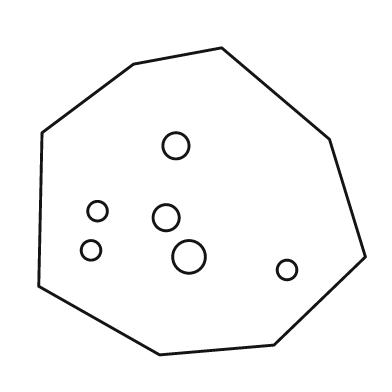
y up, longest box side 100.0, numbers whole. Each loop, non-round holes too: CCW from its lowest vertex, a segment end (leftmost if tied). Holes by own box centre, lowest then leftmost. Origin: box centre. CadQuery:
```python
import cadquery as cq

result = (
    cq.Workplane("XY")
    .moveTo(-13.0, -47.0)
    .lineTo(22.0, -44.0)
    .lineTo(50.0, -17.0)
    .lineTo(39.0, 19.0)
    .lineTo(6.0, 47.0)
    .lineTo(-21.0, 42.0)
    .lineTo(-49.0, 21.0)
    .lineTo(-50.0, -26.0)
    .close()
    .moveTo(26.0, -21.0)
    .circle(3.0)
    .moveTo(-4.0, -17.0)
    .circle(5.0)
    .moveTo(-34.0, -15.0)
    .circle(3.0)
    .moveTo(-11.0, -5.0)
    .circle(4.0)
    .moveTo(-32.0, -3.0)
    .circle(3.0)
    .moveTo(-8.0, 17.0)
    .circle(4.0)
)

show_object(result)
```